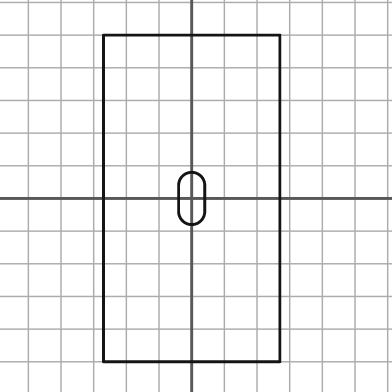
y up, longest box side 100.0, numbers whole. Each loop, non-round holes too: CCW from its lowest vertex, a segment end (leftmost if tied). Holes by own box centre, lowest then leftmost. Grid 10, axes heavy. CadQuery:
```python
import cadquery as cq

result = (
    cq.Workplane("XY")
    .moveTo(-27.0, -50.0)
    .lineTo(27.0, -50.0)
    .lineTo(27.0, 50.0)
    .lineTo(-27.0, 50.0)
    .close()
    .moveTo(-4.0, -4.0)
    .threePointArc((0.0, -8.0), (4.0, -4.0))
    .lineTo(4.0, 4.0)
    .threePointArc((0.0, 8.0), (-4.0, 4.0))
    .close()
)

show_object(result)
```